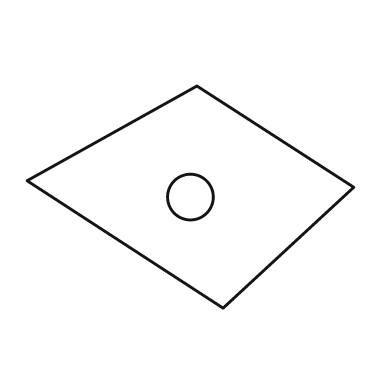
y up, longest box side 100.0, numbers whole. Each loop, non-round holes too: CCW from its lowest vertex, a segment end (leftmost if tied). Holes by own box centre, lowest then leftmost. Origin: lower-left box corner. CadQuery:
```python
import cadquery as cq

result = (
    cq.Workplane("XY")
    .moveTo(60.0, 0.0)
    .lineTo(100.0, 37.0)
    .lineTo(52.0, 68.0)
    .lineTo(0.0, 39.0)
    .close()
    .moveTo(50.0, 34.0)
    .circle(7.0)
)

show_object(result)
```